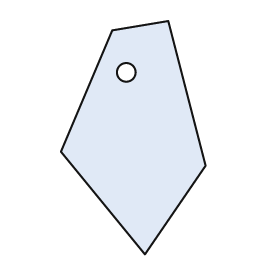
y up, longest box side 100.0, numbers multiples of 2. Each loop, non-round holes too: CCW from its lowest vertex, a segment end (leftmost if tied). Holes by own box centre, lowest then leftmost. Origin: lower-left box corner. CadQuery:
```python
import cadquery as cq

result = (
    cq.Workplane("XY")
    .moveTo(36.0, 0.0)
    .lineTo(62.0, 38.0)
    .lineTo(46.0, 100.0)
    .lineTo(22.0, 96.0)
    .lineTo(0.0, 44.0)
    .close()
    .moveTo(28.0, 78.0)
    .circle(4.0)
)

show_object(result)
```